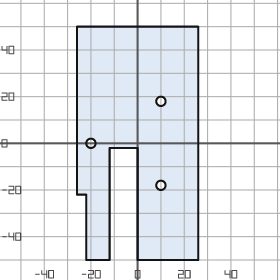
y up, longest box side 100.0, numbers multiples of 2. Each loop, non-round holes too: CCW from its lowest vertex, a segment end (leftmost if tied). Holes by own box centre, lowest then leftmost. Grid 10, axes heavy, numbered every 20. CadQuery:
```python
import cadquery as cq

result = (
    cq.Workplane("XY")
    .moveTo(-22.0, -50.0)
    .lineTo(-12.0, -50.0)
    .lineTo(-12.0, -2.0)
    .lineTo(0.0, -2.0)
    .lineTo(0.0, -50.0)
    .lineTo(26.0, -50.0)
    .lineTo(26.0, 50.0)
    .lineTo(-26.0, 50.0)
    .lineTo(-26.0, -22.0)
    .lineTo(-22.0, -22.0)
    .close()
    .moveTo(10.0, -18.0)
    .circle(2.0)
    .moveTo(-20.0, 0.0)
    .circle(2.0)
    .moveTo(10.0, 18.0)
    .circle(2.0)
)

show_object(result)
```